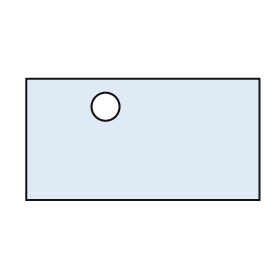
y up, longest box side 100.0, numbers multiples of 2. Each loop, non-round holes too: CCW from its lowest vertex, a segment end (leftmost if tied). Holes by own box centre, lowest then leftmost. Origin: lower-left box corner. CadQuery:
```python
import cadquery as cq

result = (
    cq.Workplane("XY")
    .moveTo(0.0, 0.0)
    .lineTo(100.0, 0.0)
    .lineTo(100.0, 52.0)
    .lineTo(0.0, 52.0)
    .close()
    .moveTo(34.0, 40.0)
    .circle(6.0)
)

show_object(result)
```